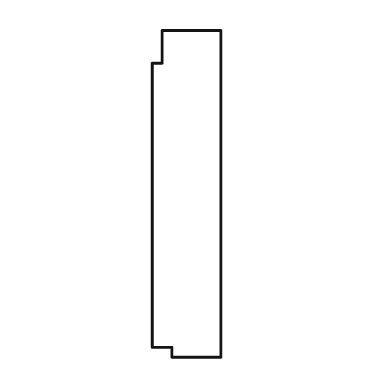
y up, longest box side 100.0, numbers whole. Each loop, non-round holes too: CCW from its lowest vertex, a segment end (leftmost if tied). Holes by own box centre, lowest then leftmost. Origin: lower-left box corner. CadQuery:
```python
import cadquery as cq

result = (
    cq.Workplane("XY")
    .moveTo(6.0, 0.0)
    .lineTo(21.0, 0.0)
    .lineTo(21.0, 100.0)
    .lineTo(3.0, 100.0)
    .lineTo(3.0, 90.0)
    .lineTo(0.0, 90.0)
    .lineTo(0.0, 3.0)
    .lineTo(6.0, 3.0)
    .close()
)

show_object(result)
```